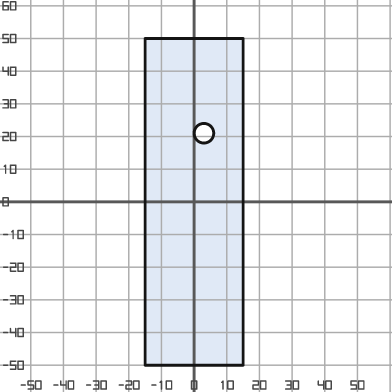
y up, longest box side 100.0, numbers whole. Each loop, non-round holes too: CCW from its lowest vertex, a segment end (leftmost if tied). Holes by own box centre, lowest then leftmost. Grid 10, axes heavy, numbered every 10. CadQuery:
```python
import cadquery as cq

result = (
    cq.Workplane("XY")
    .moveTo(-15.0, -50.0)
    .lineTo(15.0, -50.0)
    .lineTo(15.0, 50.0)
    .lineTo(-15.0, 50.0)
    .close()
    .moveTo(3.0, 21.0)
    .circle(3.0)
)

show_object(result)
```